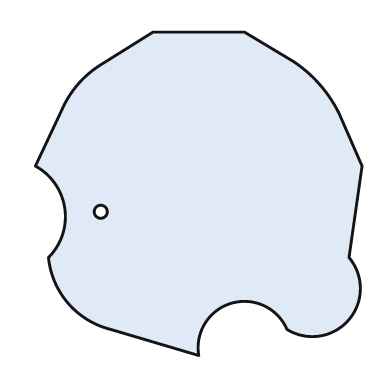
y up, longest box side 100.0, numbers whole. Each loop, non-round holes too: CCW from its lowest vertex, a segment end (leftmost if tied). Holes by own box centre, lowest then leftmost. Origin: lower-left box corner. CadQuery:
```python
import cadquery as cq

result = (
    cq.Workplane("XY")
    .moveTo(50.0, 0.0)
    .threePointArc((60.0, 16.0), (77.0, 8.0))
    .threePointArc((96.0, 11.0), (96.0, 30.0))
    .lineTo(100.0, 58.0)
    .lineTo(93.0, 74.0)
    .threePointArc((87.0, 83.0), (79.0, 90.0))
    .lineTo(64.0, 99.0)
    .lineTo(36.0, 99.0)
    .lineTo(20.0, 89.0)
    .threePointArc((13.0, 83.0), (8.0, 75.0))
    .lineTo(0.0, 58.0)
    .threePointArc((9.0, 45.0), (4.0, 30.0))
    .threePointArc((10.0, 16.0), (23.0, 8.0))
    .close()
    .moveTo(20.0, 44.0)
    .circle(2.0)
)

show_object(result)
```